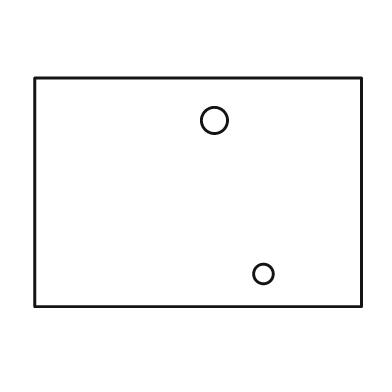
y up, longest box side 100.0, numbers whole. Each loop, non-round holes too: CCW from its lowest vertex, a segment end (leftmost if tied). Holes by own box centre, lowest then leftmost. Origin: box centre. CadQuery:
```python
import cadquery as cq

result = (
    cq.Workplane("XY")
    .moveTo(-50.0, -35.0)
    .lineTo(50.0, -35.0)
    .lineTo(50.0, 35.0)
    .lineTo(-50.0, 35.0)
    .close()
    .moveTo(20.0, -25.0)
    .circle(3.0)
    .moveTo(5.0, 22.0)
    .circle(4.0)
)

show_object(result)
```